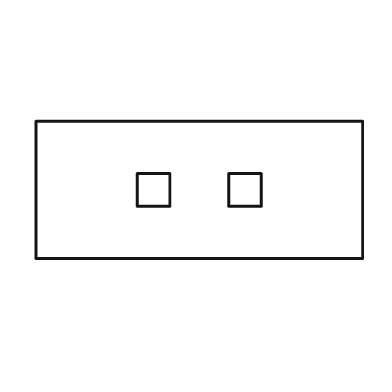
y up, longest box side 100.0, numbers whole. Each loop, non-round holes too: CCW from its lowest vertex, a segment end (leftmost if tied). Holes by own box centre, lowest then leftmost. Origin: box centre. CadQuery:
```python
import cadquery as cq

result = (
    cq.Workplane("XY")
    .moveTo(-50.0, -21.0)
    .lineTo(50.0, -21.0)
    .lineTo(50.0, 21.0)
    .lineTo(-50.0, 21.0)
    .close()
    .moveTo(-19.0, -5.0)
    .lineTo(-9.0, -5.0)
    .lineTo(-9.0, 5.0)
    .lineTo(-19.0, 5.0)
    .close()
    .moveTo(9.0, -5.0)
    .lineTo(19.0, -5.0)
    .lineTo(19.0, 5.0)
    .lineTo(9.0, 5.0)
    .close()
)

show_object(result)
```